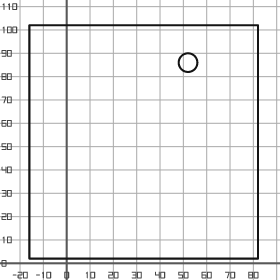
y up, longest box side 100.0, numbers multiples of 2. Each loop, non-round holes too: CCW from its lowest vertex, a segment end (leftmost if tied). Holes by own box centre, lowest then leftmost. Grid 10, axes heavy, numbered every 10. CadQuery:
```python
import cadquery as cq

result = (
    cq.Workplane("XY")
    .moveTo(-16.0, 2.0)
    .lineTo(82.0, 2.0)
    .lineTo(82.0, 102.0)
    .lineTo(-16.0, 102.0)
    .close()
    .moveTo(52.0, 86.0)
    .circle(4.0)
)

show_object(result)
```